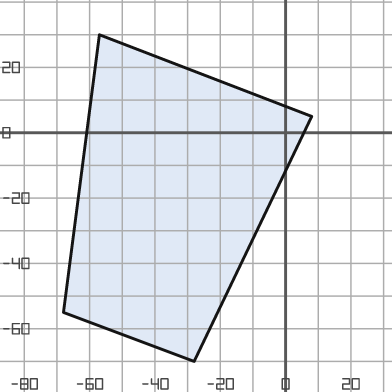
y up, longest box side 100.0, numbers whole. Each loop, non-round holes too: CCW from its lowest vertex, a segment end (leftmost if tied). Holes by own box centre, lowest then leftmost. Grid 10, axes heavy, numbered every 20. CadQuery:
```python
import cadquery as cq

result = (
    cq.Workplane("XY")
    .moveTo(-28.0, -70.0)
    .lineTo(8.0, 5.0)
    .lineTo(-57.0, 30.0)
    .lineTo(-68.0, -55.0)
    .close()
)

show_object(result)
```